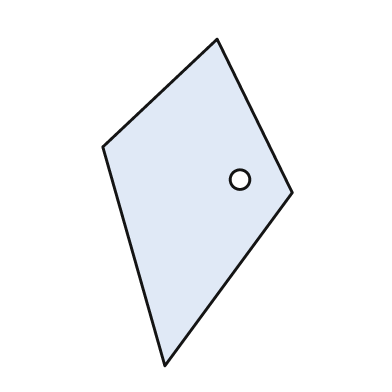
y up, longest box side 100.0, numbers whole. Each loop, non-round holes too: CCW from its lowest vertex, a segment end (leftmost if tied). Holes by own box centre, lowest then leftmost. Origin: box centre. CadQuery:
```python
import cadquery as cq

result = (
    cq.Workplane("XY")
    .moveTo(-10.0, -50.0)
    .lineTo(29.0, 3.0)
    .lineTo(6.0, 50.0)
    .lineTo(-29.0, 17.0)
    .close()
    .moveTo(13.0, 7.0)
    .circle(3.0)
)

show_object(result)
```